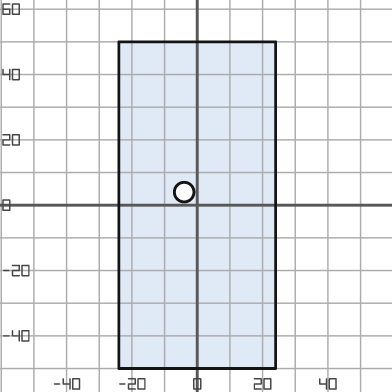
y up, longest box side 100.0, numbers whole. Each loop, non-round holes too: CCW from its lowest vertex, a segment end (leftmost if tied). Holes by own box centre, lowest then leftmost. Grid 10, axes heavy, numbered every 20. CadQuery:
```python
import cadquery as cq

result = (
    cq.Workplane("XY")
    .moveTo(-24.0, -50.0)
    .lineTo(24.0, -50.0)
    .lineTo(24.0, 50.0)
    .lineTo(-24.0, 50.0)
    .close()
    .moveTo(-4.0, 4.0)
    .circle(3.0)
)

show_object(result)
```